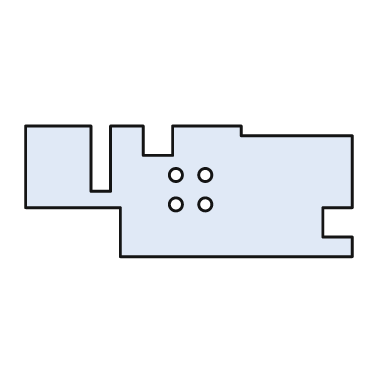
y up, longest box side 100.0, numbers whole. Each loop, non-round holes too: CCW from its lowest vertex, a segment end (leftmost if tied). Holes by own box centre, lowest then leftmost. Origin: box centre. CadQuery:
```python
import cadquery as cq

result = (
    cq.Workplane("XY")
    .moveTo(-21.0, -20.0)
    .lineTo(50.0, -20.0)
    .lineTo(50.0, -14.0)
    .lineTo(41.0, -14.0)
    .lineTo(41.0, -5.0)
    .lineTo(50.0, -5.0)
    .lineTo(50.0, 17.0)
    .lineTo(16.0, 17.0)
    .lineTo(16.0, 20.0)
    .lineTo(-5.0, 20.0)
    .lineTo(-5.0, 11.0)
    .lineTo(-14.0, 11.0)
    .lineTo(-14.0, 20.0)
    .lineTo(-24.0, 20.0)
    .lineTo(-24.0, 0.0)
    .lineTo(-30.0, 0.0)
    .lineTo(-30.0, 20.0)
    .lineTo(-50.0, 20.0)
    .lineTo(-50.0, -5.0)
    .lineTo(-21.0, -5.0)
    .close()
    .moveTo(-4.0, -4.0)
    .circle(2.0)
    .moveTo(5.0, -4.0)
    .circle(2.0)
    .moveTo(-4.0, 5.0)
    .circle(2.0)
    .moveTo(5.0, 5.0)
    .circle(2.0)
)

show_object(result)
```